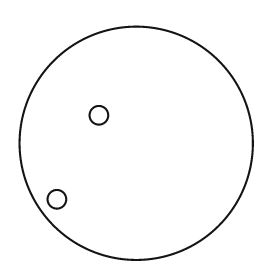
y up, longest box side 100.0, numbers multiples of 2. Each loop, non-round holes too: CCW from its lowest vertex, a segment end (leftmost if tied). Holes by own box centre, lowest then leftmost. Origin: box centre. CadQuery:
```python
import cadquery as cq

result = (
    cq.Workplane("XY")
    .moveTo(0.0, 0.0)
    .circle(50.0)
    .moveTo(-34.0, -24.0)
    .circle(4.0)
    .moveTo(-16.0, 12.0)
    .circle(4.0)
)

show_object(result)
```